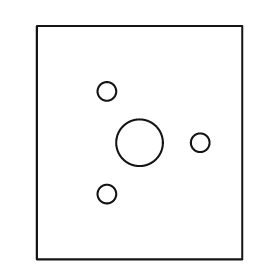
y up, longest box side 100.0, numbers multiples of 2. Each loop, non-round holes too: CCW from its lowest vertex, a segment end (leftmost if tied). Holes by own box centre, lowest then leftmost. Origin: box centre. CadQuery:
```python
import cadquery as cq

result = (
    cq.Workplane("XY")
    .moveTo(-44.0, -50.0)
    .lineTo(44.0, -50.0)
    .lineTo(44.0, 50.0)
    .lineTo(-44.0, 50.0)
    .close()
    .moveTo(-14.0, -22.0)
    .circle(4.0)
    .moveTo(0.0, 0.0)
    .circle(10.0)
    .moveTo(26.0, 0.0)
    .circle(4.0)
    .moveTo(-14.0, 22.0)
    .circle(4.0)
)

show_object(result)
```